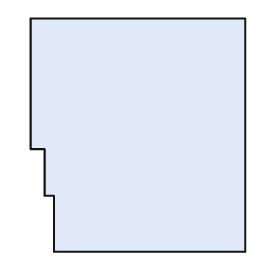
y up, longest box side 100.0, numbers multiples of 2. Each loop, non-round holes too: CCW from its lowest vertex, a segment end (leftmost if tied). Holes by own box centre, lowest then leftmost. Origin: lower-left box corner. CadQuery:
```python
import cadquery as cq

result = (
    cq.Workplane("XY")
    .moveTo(10.0, 0.0)
    .lineTo(92.0, 0.0)
    .lineTo(92.0, 100.0)
    .lineTo(0.0, 100.0)
    .lineTo(0.0, 44.0)
    .lineTo(6.0, 44.0)
    .lineTo(6.0, 24.0)
    .lineTo(10.0, 24.0)
    .close()
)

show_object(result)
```